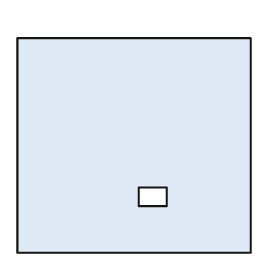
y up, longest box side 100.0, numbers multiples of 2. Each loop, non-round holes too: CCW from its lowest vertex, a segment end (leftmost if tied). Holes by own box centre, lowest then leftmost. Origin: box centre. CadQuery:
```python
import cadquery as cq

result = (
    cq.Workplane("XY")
    .moveTo(-50.0, -46.0)
    .lineTo(50.0, -46.0)
    .lineTo(50.0, 46.0)
    .lineTo(-50.0, 46.0)
    .close()
    .moveTo(2.0, -26.0)
    .lineTo(14.0, -26.0)
    .lineTo(14.0, -18.0)
    .lineTo(2.0, -18.0)
    .close()
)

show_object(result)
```